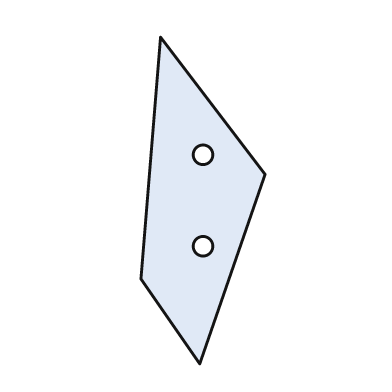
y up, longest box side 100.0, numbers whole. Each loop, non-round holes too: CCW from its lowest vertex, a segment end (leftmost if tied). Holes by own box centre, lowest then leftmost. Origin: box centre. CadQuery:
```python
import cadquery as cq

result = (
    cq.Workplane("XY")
    .moveTo(-1.0, -50.0)
    .lineTo(19.0, 8.0)
    .lineTo(-13.0, 50.0)
    .lineTo(-19.0, -24.0)
    .close()
    .moveTo(0.0, -14.0)
    .circle(3.0)
    .moveTo(0.0, 14.0)
    .circle(3.0)
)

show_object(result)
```